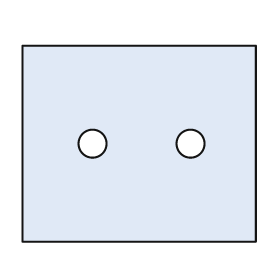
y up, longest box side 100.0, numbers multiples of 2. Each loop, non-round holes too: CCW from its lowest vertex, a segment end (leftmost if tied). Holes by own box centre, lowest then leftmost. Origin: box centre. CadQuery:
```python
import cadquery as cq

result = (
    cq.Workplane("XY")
    .moveTo(-50.0, -42.0)
    .lineTo(50.0, -42.0)
    .lineTo(50.0, 42.0)
    .lineTo(-50.0, 42.0)
    .close()
    .moveTo(-20.0, 0.0)
    .circle(6.0)
    .moveTo(22.0, 0.0)
    .circle(6.0)
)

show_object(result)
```